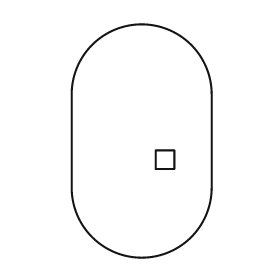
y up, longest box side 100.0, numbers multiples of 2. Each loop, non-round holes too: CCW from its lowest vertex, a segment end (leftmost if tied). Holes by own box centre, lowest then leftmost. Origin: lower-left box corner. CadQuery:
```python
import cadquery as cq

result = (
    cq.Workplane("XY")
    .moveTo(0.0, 30.0)
    .threePointArc((30.0, 0.0), (60.0, 30.0))
    .lineTo(60.0, 70.0)
    .threePointArc((30.0, 100.0), (0.0, 70.0))
    .close()
    .moveTo(36.0, 38.0)
    .lineTo(44.0, 38.0)
    .lineTo(44.0, 46.0)
    .lineTo(36.0, 46.0)
    .close()
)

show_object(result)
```